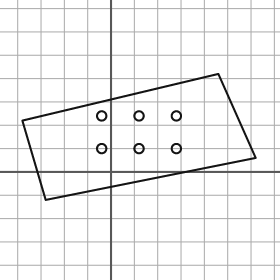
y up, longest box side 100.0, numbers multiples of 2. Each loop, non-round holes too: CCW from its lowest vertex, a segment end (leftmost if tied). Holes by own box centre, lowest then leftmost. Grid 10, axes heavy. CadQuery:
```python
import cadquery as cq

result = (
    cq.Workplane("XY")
    .moveTo(-28.0, -12.0)
    .lineTo(62.0, 6.0)
    .lineTo(46.0, 42.0)
    .lineTo(-38.0, 22.0)
    .close()
    .moveTo(-4.0, 10.0)
    .circle(2.0)
    .moveTo(12.0, 10.0)
    .circle(2.0)
    .moveTo(28.0, 10.0)
    .circle(2.0)
    .moveTo(-4.0, 24.0)
    .circle(2.0)
    .moveTo(12.0, 24.0)
    .circle(2.0)
    .moveTo(28.0, 24.0)
    .circle(2.0)
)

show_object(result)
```